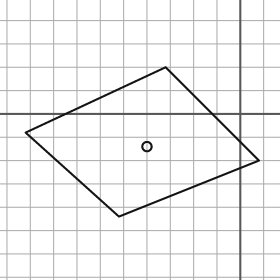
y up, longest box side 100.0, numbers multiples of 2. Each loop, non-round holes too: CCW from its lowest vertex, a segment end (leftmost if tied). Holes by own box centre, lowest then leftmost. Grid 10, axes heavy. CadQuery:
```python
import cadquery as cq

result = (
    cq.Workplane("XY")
    .moveTo(-52.0, -44.0)
    .lineTo(8.0, -20.0)
    .lineTo(-32.0, 20.0)
    .lineTo(-92.0, -8.0)
    .close()
    .moveTo(-40.0, -14.0)
    .circle(2.0)
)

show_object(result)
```